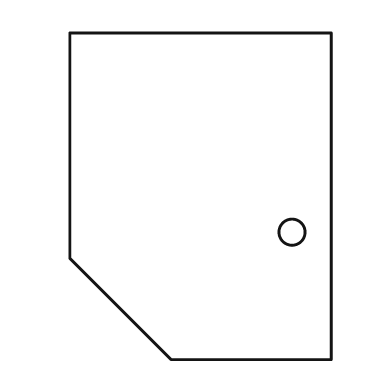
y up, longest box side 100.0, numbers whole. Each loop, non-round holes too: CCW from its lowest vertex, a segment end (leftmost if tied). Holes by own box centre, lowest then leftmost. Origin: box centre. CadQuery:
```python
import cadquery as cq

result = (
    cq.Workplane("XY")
    .moveTo(-9.0, -50.0)
    .lineTo(40.0, -50.0)
    .lineTo(40.0, 50.0)
    .lineTo(-40.0, 50.0)
    .lineTo(-40.0, -19.0)
    .close()
    .moveTo(28.0, -11.0)
    .circle(4.0)
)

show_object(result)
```